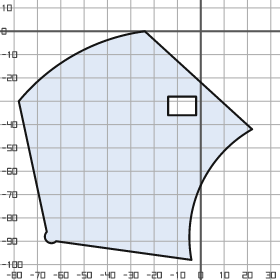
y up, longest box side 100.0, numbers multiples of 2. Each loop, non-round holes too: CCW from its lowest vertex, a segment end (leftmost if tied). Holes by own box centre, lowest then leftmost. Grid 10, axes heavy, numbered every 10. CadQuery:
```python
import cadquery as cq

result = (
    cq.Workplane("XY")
    .moveTo(-4.0, -98.0)
    .threePointArc((0.0, -66.0), (22.0, -42.0))
    .lineTo(-24.0, 0.0)
    .threePointArc((-54.0, -10.0), (-78.0, -30.0))
    .lineTo(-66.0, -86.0)
    .threePointArc((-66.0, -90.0), (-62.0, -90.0))
    .close()
    .moveTo(-14.0, -36.0)
    .lineTo(-2.0, -36.0)
    .lineTo(-2.0, -28.0)
    .lineTo(-14.0, -28.0)
    .close()
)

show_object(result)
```